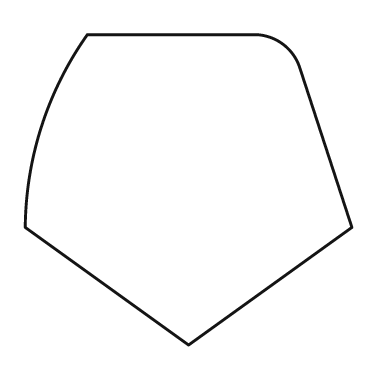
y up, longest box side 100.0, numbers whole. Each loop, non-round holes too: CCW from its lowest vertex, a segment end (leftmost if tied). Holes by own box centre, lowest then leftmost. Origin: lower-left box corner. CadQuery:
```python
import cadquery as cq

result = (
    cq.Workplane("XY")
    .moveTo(50.0, 0.0)
    .lineTo(100.0, 36.0)
    .lineTo(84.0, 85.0)
    .threePointArc((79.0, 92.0), (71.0, 95.0))
    .lineTo(19.0, 95.0)
    .threePointArc((5.0, 67.0), (0.0, 36.0))
    .close()
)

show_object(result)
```